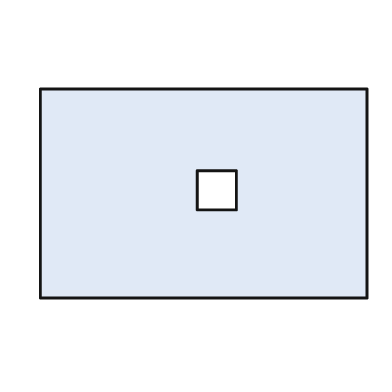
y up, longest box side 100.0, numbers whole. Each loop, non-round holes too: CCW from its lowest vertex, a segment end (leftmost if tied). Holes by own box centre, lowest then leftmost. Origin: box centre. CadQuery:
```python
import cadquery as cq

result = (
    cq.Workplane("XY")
    .moveTo(-50.0, -32.0)
    .lineTo(50.0, -32.0)
    .lineTo(50.0, 32.0)
    .lineTo(-50.0, 32.0)
    .close()
    .moveTo(-2.0, -5.0)
    .lineTo(10.0, -5.0)
    .lineTo(10.0, 7.0)
    .lineTo(-2.0, 7.0)
    .close()
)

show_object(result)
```